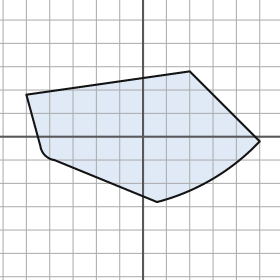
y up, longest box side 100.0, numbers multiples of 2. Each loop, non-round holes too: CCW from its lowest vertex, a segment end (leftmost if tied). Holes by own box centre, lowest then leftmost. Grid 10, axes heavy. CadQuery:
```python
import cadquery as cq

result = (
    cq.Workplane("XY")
    .moveTo(6.0, -28.0)
    .threePointArc((30.0, -18.0), (50.0, -2.0))
    .lineTo(20.0, 28.0)
    .lineTo(-50.0, 18.0)
    .lineTo(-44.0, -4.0)
    .threePointArc((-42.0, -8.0), (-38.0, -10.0))
    .close()
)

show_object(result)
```